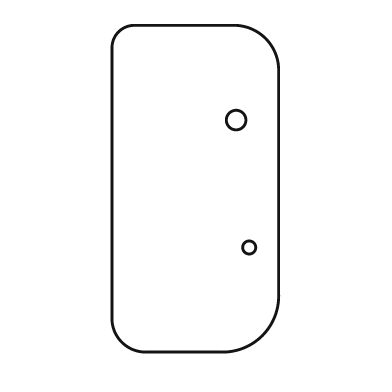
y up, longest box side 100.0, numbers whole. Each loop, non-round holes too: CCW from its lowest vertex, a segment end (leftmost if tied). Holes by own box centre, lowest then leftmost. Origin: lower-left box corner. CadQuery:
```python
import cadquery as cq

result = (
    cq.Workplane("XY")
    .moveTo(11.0, 0.0)
    .lineTo(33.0, 0.0)
    .threePointArc((46.0, 5.0), (51.0, 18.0))
    .lineTo(51.0, 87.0)
    .threePointArc((47.0, 96.0), (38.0, 100.0))
    .lineTo(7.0, 100.0)
    .threePointArc((2.0, 98.0), (0.0, 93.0))
    .lineTo(0.0, 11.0)
    .threePointArc((3.0, 3.0), (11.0, 0.0))
    .close()
    .moveTo(42.0, 32.0)
    .circle(2.0)
    .moveTo(38.0, 71.0)
    .circle(3.0)
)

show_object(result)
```